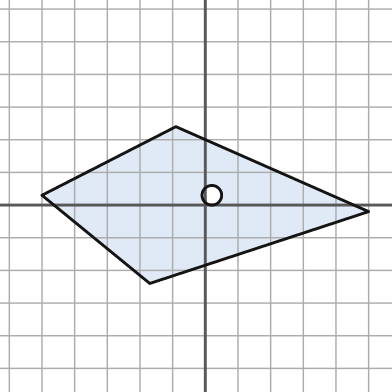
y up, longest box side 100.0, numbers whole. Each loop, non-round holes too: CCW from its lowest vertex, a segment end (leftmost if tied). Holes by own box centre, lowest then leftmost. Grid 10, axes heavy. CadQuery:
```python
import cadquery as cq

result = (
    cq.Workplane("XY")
    .moveTo(-17.0, -24.0)
    .lineTo(50.0, -2.0)
    .lineTo(-9.0, 24.0)
    .lineTo(-50.0, 3.0)
    .close()
    .moveTo(2.0, 3.0)
    .circle(3.0)
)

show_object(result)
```